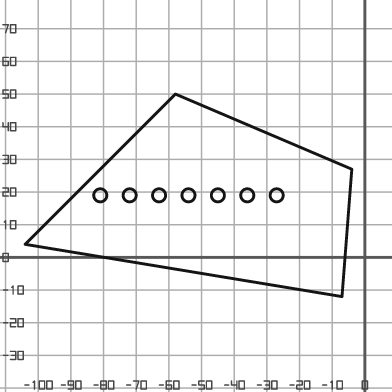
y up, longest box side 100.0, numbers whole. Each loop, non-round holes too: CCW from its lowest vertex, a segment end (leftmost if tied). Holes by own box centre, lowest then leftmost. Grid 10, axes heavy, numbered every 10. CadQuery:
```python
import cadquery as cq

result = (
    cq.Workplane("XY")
    .moveTo(-7.0, -12.0)
    .lineTo(-4.0, 27.0)
    .lineTo(-58.0, 50.0)
    .lineTo(-104.0, 4.0)
    .close()
    .moveTo(-81.0, 19.0)
    .circle(2.0)
    .moveTo(-72.0, 19.0)
    .circle(2.0)
    .moveTo(-63.0, 19.0)
    .circle(2.0)
    .moveTo(-54.0, 19.0)
    .circle(2.0)
    .moveTo(-45.0, 19.0)
    .circle(2.0)
    .moveTo(-36.0, 19.0)
    .circle(2.0)
    .moveTo(-27.0, 19.0)
    .circle(2.0)
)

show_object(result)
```